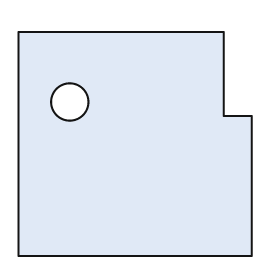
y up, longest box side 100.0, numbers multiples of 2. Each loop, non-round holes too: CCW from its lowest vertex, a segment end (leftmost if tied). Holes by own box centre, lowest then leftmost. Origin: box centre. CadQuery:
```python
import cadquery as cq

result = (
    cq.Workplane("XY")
    .moveTo(-50.0, -48.0)
    .lineTo(50.0, -48.0)
    .lineTo(50.0, 12.0)
    .lineTo(38.0, 12.0)
    .lineTo(38.0, 48.0)
    .lineTo(-50.0, 48.0)
    .close()
    .moveTo(-28.0, 18.0)
    .circle(8.0)
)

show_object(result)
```